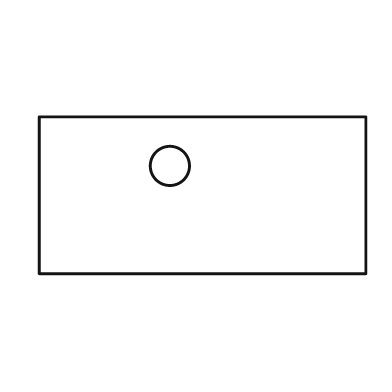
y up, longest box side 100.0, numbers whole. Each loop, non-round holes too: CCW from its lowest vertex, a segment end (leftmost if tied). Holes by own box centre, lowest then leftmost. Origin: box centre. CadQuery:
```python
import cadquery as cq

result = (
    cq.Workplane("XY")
    .moveTo(-50.0, -24.0)
    .lineTo(50.0, -24.0)
    .lineTo(50.0, 24.0)
    .lineTo(-50.0, 24.0)
    .close()
    .moveTo(-10.0, 9.0)
    .circle(6.0)
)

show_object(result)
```